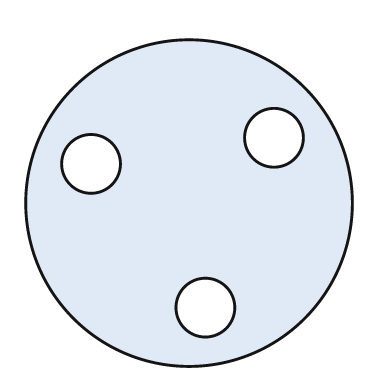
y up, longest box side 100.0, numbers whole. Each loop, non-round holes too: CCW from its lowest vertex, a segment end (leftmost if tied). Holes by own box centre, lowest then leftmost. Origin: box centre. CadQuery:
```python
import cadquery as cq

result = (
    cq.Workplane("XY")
    .moveTo(0.0, 0.0)
    .circle(50.0)
    .moveTo(5.0, -32.0)
    .circle(9.0)
    .moveTo(-30.0, 12.0)
    .circle(9.0)
    .moveTo(26.0, 20.0)
    .circle(9.0)
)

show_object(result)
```